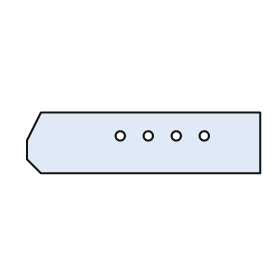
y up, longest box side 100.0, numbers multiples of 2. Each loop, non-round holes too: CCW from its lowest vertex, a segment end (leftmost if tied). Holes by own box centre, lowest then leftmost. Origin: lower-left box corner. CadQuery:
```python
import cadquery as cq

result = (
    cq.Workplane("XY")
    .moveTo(6.0, 0.0)
    .lineTo(100.0, 0.0)
    .lineTo(100.0, 26.0)
    .lineTo(6.0, 26.0)
    .lineTo(0.0, 14.0)
    .lineTo(0.0, 6.0)
    .close()
    .moveTo(40.0, 16.0)
    .circle(2.0)
    .moveTo(52.0, 16.0)
    .circle(2.0)
    .moveTo(64.0, 16.0)
    .circle(2.0)
    .moveTo(76.0, 16.0)
    .circle(2.0)
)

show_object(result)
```